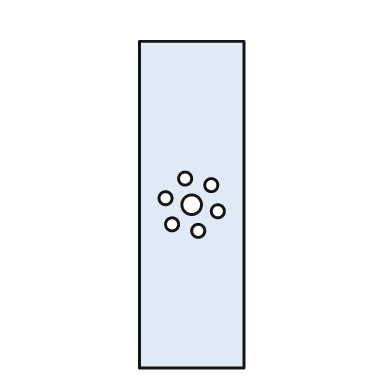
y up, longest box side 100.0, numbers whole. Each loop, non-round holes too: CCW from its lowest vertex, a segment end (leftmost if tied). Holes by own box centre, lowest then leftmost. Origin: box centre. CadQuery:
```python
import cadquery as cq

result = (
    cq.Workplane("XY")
    .moveTo(-16.0, -50.0)
    .lineTo(16.0, -50.0)
    .lineTo(16.0, 50.0)
    .lineTo(-16.0, 50.0)
    .close()
    .moveTo(2.0, -8.0)
    .circle(2.0)
    .moveTo(-6.0, -6.0)
    .circle(2.0)
    .moveTo(8.0, -2.0)
    .circle(2.0)
    .moveTo(0.0, 0.0)
    .circle(3.0)
    .moveTo(-8.0, 2.0)
    .circle(2.0)
    .moveTo(6.0, 6.0)
    .circle(2.0)
    .moveTo(-2.0, 8.0)
    .circle(2.0)
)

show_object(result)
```